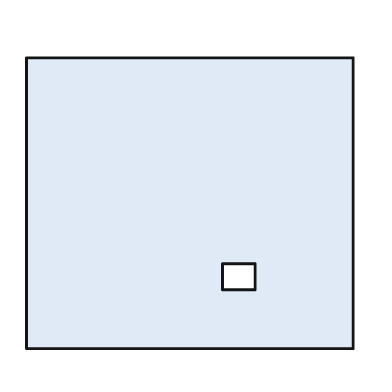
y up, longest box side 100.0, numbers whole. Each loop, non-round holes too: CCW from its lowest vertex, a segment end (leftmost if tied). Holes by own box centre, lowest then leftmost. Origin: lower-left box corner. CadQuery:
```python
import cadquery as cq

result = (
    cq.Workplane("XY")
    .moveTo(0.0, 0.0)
    .lineTo(100.0, 0.0)
    .lineTo(100.0, 89.0)
    .lineTo(0.0, 89.0)
    .close()
    .moveTo(60.0, 18.0)
    .lineTo(70.0, 18.0)
    .lineTo(70.0, 26.0)
    .lineTo(60.0, 26.0)
    .close()
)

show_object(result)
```